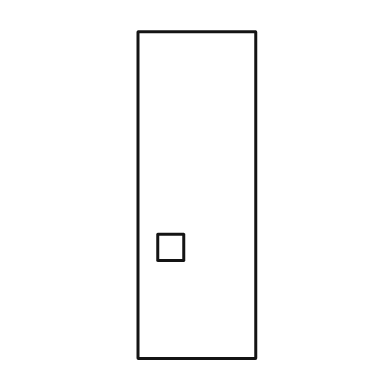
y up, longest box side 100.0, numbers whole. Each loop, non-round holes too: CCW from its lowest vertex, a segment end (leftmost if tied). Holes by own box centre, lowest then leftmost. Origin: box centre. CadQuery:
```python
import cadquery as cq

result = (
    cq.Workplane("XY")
    .moveTo(-18.0, -50.0)
    .lineTo(18.0, -50.0)
    .lineTo(18.0, 50.0)
    .lineTo(-18.0, 50.0)
    .close()
    .moveTo(-12.0, -20.0)
    .lineTo(-4.0, -20.0)
    .lineTo(-4.0, -12.0)
    .lineTo(-12.0, -12.0)
    .close()
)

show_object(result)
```